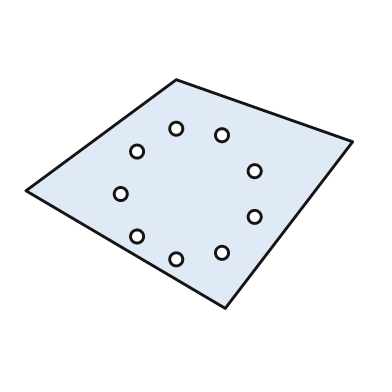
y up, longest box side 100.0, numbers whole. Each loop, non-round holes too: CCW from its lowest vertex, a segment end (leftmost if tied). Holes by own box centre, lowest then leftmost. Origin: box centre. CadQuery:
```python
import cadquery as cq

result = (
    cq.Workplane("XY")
    .moveTo(11.0, -35.0)
    .lineTo(50.0, 16.0)
    .lineTo(-4.0, 35.0)
    .lineTo(-50.0, 1.0)
    .close()
    .moveTo(-4.0, -20.0)
    .circle(2.0)
    .moveTo(10.0, -18.0)
    .circle(2.0)
    .moveTo(-16.0, -13.0)
    .circle(2.0)
    .moveTo(20.0, -7.0)
    .circle(2.0)
    .moveTo(-21.0, 0.0)
    .circle(2.0)
    .moveTo(20.0, 7.0)
    .circle(2.0)
    .moveTo(-16.0, 13.0)
    .circle(2.0)
    .moveTo(10.0, 18.0)
    .circle(2.0)
    .moveTo(-4.0, 20.0)
    .circle(2.0)
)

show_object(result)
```